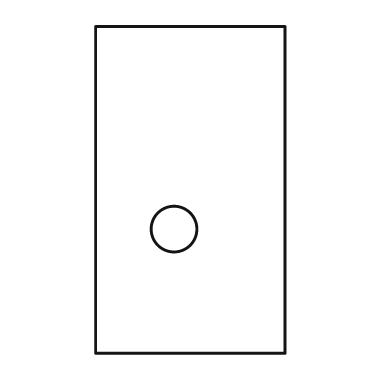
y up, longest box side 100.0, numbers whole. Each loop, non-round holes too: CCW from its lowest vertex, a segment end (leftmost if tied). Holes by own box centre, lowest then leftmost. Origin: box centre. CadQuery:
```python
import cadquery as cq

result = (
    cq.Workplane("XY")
    .moveTo(-29.0, -50.0)
    .lineTo(29.0, -50.0)
    .lineTo(29.0, 50.0)
    .lineTo(-29.0, 50.0)
    .close()
    .moveTo(-5.0, -12.0)
    .circle(7.0)
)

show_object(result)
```